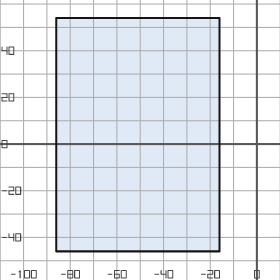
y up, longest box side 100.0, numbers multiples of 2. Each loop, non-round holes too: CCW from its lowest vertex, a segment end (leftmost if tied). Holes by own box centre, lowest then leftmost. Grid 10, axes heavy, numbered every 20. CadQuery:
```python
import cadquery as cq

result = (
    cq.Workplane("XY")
    .moveTo(-86.0, -46.0)
    .lineTo(-16.0, -46.0)
    .lineTo(-16.0, 54.0)
    .lineTo(-86.0, 54.0)
    .close()
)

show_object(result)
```